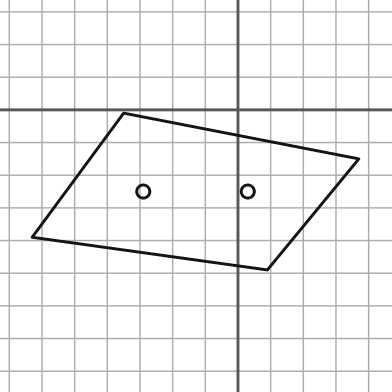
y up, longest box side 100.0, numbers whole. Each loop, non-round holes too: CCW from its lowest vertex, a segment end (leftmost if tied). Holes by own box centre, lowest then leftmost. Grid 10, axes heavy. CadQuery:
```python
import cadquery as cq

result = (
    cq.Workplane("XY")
    .moveTo(9.0, -49.0)
    .lineTo(37.0, -15.0)
    .lineTo(-35.0, -1.0)
    .lineTo(-63.0, -39.0)
    .close()
    .moveTo(-29.0, -25.0)
    .circle(2.0)
    .moveTo(3.0, -25.0)
    .circle(2.0)
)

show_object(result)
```